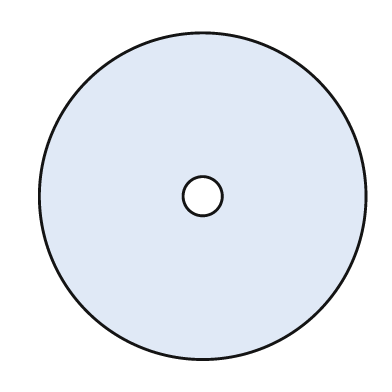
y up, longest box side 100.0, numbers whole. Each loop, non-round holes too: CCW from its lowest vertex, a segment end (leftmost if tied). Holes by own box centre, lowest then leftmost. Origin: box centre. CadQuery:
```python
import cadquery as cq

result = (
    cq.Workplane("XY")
    .moveTo(0.0, 0.0)
    .circle(50.0)
    .moveTo(0.0, 0.0)
    .circle(6.0)
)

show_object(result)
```